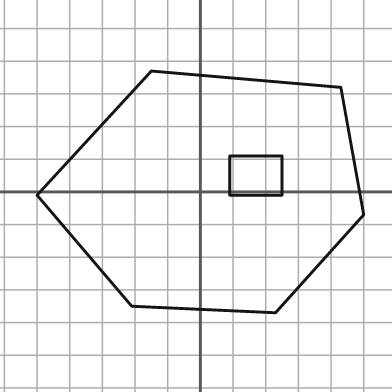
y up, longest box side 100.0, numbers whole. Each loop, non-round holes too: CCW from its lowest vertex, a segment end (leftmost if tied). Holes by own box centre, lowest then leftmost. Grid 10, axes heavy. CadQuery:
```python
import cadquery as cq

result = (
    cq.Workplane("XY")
    .moveTo(23.0, -37.0)
    .lineTo(50.0, -7.0)
    .lineTo(43.0, 32.0)
    .lineTo(-15.0, 37.0)
    .lineTo(-50.0, -1.0)
    .lineTo(-21.0, -35.0)
    .close()
    .moveTo(9.0, -1.0)
    .lineTo(25.0, -1.0)
    .lineTo(25.0, 11.0)
    .lineTo(9.0, 11.0)
    .close()
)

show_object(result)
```